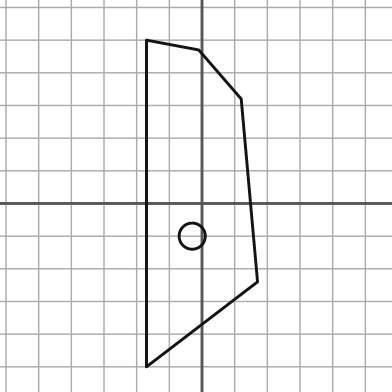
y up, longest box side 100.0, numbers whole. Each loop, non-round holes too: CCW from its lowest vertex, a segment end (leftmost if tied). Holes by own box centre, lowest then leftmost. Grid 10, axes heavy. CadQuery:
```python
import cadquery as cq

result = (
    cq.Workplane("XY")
    .moveTo(-17.0, -50.0)
    .lineTo(17.0, -24.0)
    .lineTo(12.0, 32.0)
    .lineTo(-1.0, 47.0)
    .lineTo(-17.0, 50.0)
    .close()
    .moveTo(-3.0, -10.0)
    .circle(4.0)
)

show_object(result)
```